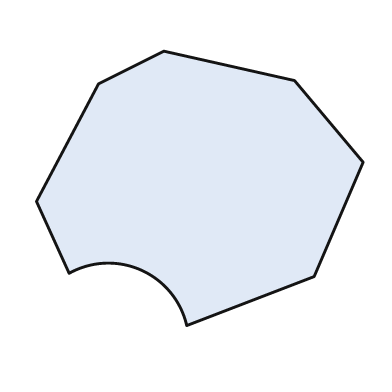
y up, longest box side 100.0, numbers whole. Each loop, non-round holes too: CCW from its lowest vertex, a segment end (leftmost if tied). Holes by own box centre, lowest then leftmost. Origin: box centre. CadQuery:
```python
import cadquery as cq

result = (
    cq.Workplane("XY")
    .moveTo(-4.0, -42.0)
    .lineTo(35.0, -27.0)
    .lineTo(50.0, 8.0)
    .lineTo(29.0, 33.0)
    .lineTo(-11.0, 42.0)
    .lineTo(-31.0, 32.0)
    .lineTo(-50.0, -4.0)
    .lineTo(-40.0, -26.0)
    .threePointArc((-18.0, -25.0), (-4.0, -42.0))
    .close()
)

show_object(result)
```